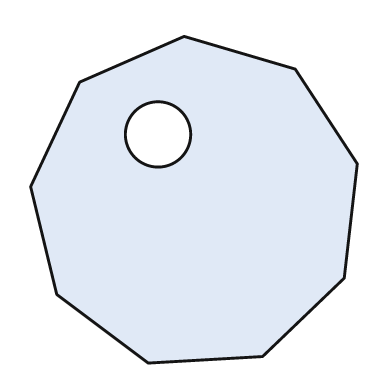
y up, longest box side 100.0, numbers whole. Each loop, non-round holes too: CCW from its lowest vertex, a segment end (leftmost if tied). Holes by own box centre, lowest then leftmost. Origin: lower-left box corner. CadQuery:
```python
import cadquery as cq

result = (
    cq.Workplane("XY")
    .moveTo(36.0, 0.0)
    .lineTo(71.0, 2.0)
    .lineTo(96.0, 26.0)
    .lineTo(100.0, 61.0)
    .lineTo(81.0, 90.0)
    .lineTo(47.0, 100.0)
    .lineTo(15.0, 86.0)
    .lineTo(0.0, 54.0)
    .lineTo(8.0, 21.0)
    .close()
    .moveTo(39.0, 70.0)
    .circle(10.0)
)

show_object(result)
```